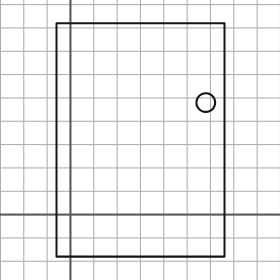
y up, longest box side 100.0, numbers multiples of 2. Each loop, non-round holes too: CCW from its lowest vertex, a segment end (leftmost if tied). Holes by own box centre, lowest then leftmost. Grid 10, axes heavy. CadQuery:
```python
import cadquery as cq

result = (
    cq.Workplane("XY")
    .moveTo(-6.0, -18.0)
    .lineTo(66.0, -18.0)
    .lineTo(66.0, 82.0)
    .lineTo(-6.0, 82.0)
    .close()
    .moveTo(58.0, 48.0)
    .circle(4.0)
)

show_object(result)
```